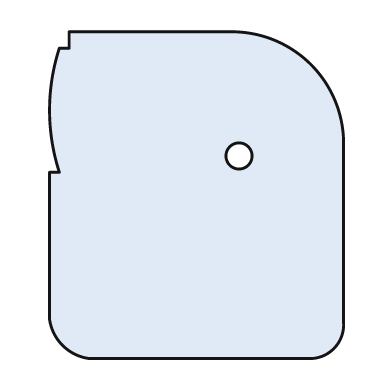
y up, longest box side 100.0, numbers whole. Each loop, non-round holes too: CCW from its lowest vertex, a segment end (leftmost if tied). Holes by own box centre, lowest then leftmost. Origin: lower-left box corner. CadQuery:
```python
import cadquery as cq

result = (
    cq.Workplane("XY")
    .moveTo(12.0, 0.0)
    .lineTo(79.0, 0.0)
    .threePointArc((87.0, 3.0), (90.0, 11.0))
    .lineTo(90.0, 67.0)
    .threePointArc((80.0, 90.0), (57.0, 100.0))
    .lineTo(6.0, 100.0)
    .lineTo(6.0, 95.0)
    .lineTo(3.0, 95.0)
    .threePointArc((0.0, 76.0), (3.0, 57.0))
    .lineTo(0.0, 57.0)
    .lineTo(0.0, 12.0)
    .threePointArc((4.0, 4.0), (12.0, 0.0))
    .close()
    .moveTo(58.0, 62.0)
    .circle(4.0)
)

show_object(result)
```